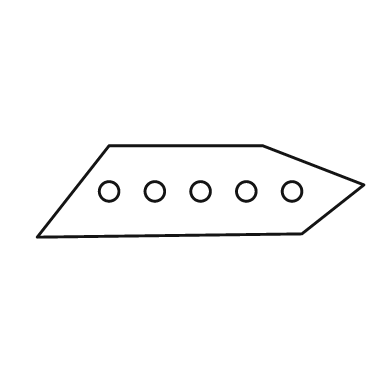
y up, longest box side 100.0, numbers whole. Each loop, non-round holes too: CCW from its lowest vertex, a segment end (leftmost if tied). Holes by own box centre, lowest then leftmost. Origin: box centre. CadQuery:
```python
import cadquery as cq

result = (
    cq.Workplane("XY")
    .moveTo(-50.0, -14.0)
    .lineTo(31.0, -13.0)
    .lineTo(50.0, 2.0)
    .lineTo(19.0, 14.0)
    .lineTo(-28.0, 14.0)
    .close()
    .moveTo(-28.0, 0.0)
    .circle(3.0)
    .moveTo(-14.0, 0.0)
    .circle(3.0)
    .moveTo(0.0, 0.0)
    .circle(3.0)
    .moveTo(14.0, 0.0)
    .circle(3.0)
    .moveTo(28.0, 0.0)
    .circle(3.0)
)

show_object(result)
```